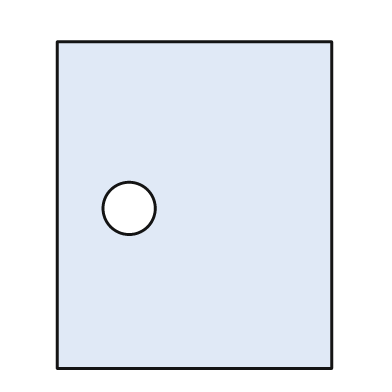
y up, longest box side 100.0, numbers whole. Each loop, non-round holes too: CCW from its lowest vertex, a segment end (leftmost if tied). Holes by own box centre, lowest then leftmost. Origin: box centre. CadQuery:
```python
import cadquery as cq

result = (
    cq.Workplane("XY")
    .moveTo(-42.0, -50.0)
    .lineTo(42.0, -50.0)
    .lineTo(42.0, 50.0)
    .lineTo(-42.0, 50.0)
    .close()
    .moveTo(-20.0, -1.0)
    .circle(8.0)
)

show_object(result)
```